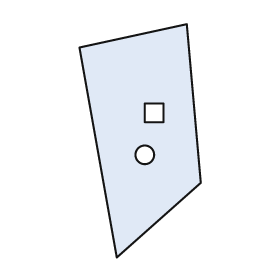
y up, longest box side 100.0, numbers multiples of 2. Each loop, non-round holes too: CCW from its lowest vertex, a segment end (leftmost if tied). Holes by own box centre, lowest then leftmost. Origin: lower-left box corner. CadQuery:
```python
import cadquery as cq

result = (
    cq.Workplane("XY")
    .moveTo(16.0, 0.0)
    .lineTo(52.0, 32.0)
    .lineTo(46.0, 100.0)
    .lineTo(0.0, 90.0)
    .close()
    .moveTo(28.0, 44.0)
    .circle(4.0)
    .moveTo(28.0, 58.0)
    .lineTo(36.0, 58.0)
    .lineTo(36.0, 66.0)
    .lineTo(28.0, 66.0)
    .close()
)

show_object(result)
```